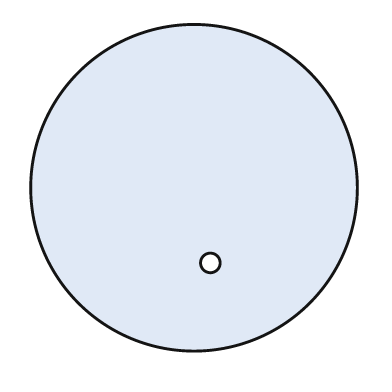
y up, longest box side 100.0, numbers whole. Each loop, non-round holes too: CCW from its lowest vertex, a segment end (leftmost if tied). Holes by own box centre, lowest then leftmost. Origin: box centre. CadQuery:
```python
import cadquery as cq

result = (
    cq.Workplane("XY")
    .moveTo(0.0, 0.0)
    .circle(50.0)
    .moveTo(5.0, -23.0)
    .circle(3.0)
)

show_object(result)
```